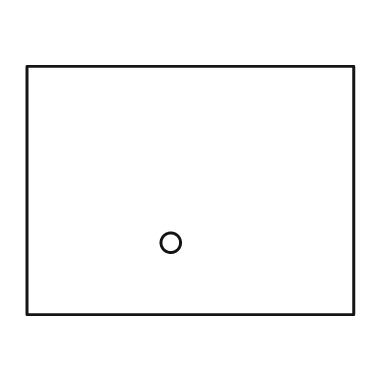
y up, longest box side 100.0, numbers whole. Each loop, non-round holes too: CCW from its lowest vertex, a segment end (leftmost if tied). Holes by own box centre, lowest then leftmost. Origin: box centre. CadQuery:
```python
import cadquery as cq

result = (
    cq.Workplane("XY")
    .moveTo(-50.0, -38.0)
    .lineTo(50.0, -38.0)
    .lineTo(50.0, 38.0)
    .lineTo(-50.0, 38.0)
    .close()
    .moveTo(-6.0, -16.0)
    .circle(3.0)
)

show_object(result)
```